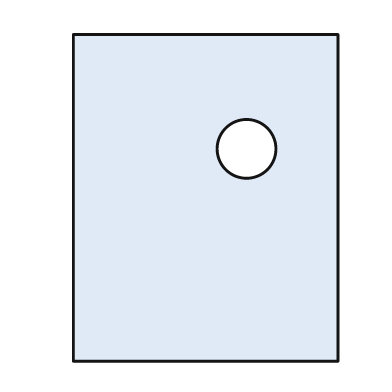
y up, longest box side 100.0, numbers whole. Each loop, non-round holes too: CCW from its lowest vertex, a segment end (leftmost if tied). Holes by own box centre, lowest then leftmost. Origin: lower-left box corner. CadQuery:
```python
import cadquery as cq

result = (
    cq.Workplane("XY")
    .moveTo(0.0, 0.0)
    .lineTo(81.0, 0.0)
    .lineTo(81.0, 100.0)
    .lineTo(0.0, 100.0)
    .close()
    .moveTo(53.0, 65.0)
    .circle(9.0)
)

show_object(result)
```